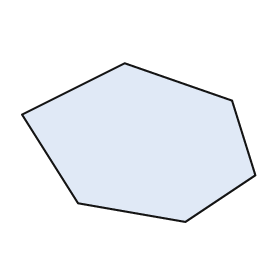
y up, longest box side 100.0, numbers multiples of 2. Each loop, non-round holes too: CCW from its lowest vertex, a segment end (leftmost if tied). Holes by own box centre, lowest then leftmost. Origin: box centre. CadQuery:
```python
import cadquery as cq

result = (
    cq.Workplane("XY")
    .moveTo(20.0, -34.0)
    .lineTo(50.0, -14.0)
    .lineTo(40.0, 18.0)
    .lineTo(-6.0, 34.0)
    .lineTo(-50.0, 12.0)
    .lineTo(-26.0, -26.0)
    .close()
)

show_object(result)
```